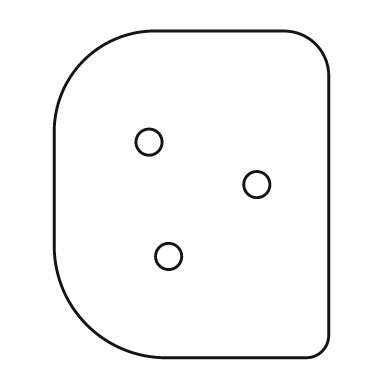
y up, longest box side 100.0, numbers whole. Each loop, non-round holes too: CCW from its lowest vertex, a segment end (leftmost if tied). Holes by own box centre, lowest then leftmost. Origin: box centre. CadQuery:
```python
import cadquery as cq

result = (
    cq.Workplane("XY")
    .moveTo(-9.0, -50.0)
    .lineTo(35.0, -50.0)
    .threePointArc((40.0, -48.0), (42.0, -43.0))
    .lineTo(42.0, 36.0)
    .threePointArc((38.0, 46.0), (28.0, 50.0))
    .lineTo(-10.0, 50.0)
    .threePointArc((-33.0, 41.0), (-42.0, 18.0))
    .lineTo(-42.0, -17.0)
    .threePointArc((-32.0, -40.0), (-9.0, -50.0))
    .close()
    .moveTo(-7.0, -19.0)
    .circle(4.0)
    .moveTo(20.0, 3.0)
    .circle(4.0)
    .moveTo(-13.0, 16.0)
    .circle(4.0)
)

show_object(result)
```